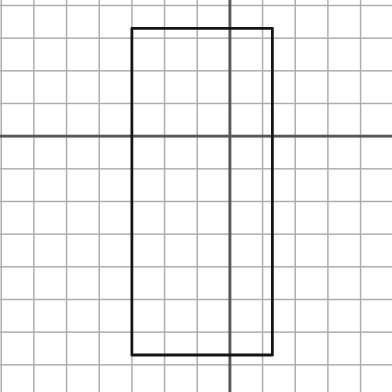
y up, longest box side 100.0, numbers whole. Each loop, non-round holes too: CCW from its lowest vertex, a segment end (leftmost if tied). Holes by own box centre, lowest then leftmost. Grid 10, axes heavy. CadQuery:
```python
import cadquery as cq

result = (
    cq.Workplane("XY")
    .moveTo(-30.0, -67.0)
    .lineTo(13.0, -67.0)
    .lineTo(13.0, 33.0)
    .lineTo(-30.0, 33.0)
    .close()
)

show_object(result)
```